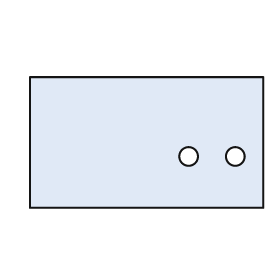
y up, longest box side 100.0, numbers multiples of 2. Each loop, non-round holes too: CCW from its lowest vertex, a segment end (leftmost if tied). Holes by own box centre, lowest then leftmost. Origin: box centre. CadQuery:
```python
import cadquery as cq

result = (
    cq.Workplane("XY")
    .moveTo(-50.0, -28.0)
    .lineTo(50.0, -28.0)
    .lineTo(50.0, 28.0)
    .lineTo(-50.0, 28.0)
    .close()
    .moveTo(18.0, -6.0)
    .circle(4.0)
    .moveTo(38.0, -6.0)
    .circle(4.0)
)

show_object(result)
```